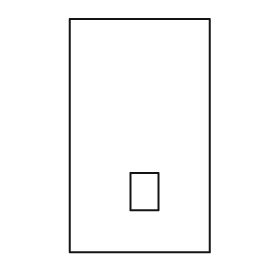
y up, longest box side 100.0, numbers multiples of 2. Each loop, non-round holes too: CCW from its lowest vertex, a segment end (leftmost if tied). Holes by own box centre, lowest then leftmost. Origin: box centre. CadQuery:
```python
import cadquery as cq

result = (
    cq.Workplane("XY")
    .moveTo(-30.0, -50.0)
    .lineTo(30.0, -50.0)
    .lineTo(30.0, 50.0)
    .lineTo(-30.0, 50.0)
    .close()
    .moveTo(-4.0, -32.0)
    .lineTo(8.0, -32.0)
    .lineTo(8.0, -16.0)
    .lineTo(-4.0, -16.0)
    .close()
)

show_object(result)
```